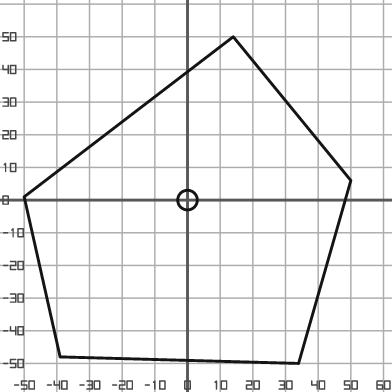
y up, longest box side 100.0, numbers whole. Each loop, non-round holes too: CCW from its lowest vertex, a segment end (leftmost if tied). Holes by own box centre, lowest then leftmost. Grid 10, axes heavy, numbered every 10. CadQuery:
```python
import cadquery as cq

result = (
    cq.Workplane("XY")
    .moveTo(34.0, -50.0)
    .lineTo(50.0, 6.0)
    .lineTo(14.0, 50.0)
    .lineTo(-50.0, 1.0)
    .lineTo(-39.0, -48.0)
    .close()
    .moveTo(0.0, 0.0)
    .circle(3.0)
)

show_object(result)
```